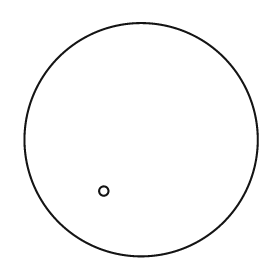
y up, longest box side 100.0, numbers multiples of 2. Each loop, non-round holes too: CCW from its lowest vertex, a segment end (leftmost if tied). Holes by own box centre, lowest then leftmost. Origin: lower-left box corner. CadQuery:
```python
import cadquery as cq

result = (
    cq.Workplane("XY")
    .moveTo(50.0, 50.0)
    .circle(50.0)
    .moveTo(34.0, 28.0)
    .circle(2.0)
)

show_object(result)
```